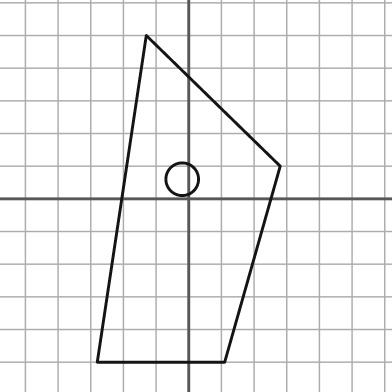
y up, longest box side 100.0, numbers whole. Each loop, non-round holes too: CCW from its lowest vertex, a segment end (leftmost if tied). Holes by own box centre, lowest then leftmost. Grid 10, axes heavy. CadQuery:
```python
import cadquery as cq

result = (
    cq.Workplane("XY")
    .moveTo(-28.0, -50.0)
    .lineTo(11.0, -50.0)
    .lineTo(28.0, 10.0)
    .lineTo(-13.0, 50.0)
    .close()
    .moveTo(-2.0, 6.0)
    .circle(5.0)
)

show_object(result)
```